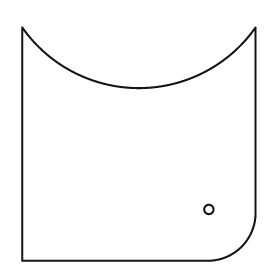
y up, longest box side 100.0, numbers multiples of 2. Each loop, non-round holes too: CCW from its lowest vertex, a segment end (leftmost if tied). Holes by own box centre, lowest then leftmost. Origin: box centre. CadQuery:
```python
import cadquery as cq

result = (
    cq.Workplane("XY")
    .moveTo(-50.0, -50.0)
    .lineTo(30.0, -50.0)
    .threePointArc((44.0, -44.0), (50.0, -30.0))
    .lineTo(50.0, 50.0)
    .threePointArc((0.0, 24.0), (-50.0, 50.0))
    .close()
    .moveTo(30.0, -28.0)
    .circle(2.0)
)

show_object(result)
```